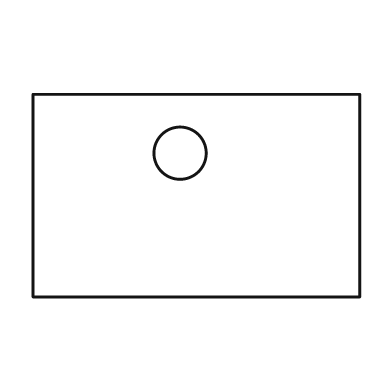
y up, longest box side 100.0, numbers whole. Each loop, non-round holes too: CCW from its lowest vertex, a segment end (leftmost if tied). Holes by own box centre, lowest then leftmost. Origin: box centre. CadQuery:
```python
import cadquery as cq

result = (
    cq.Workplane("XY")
    .moveTo(-50.0, -31.0)
    .lineTo(50.0, -31.0)
    .lineTo(50.0, 31.0)
    .lineTo(-50.0, 31.0)
    .close()
    .moveTo(-5.0, 13.0)
    .circle(8.0)
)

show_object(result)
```